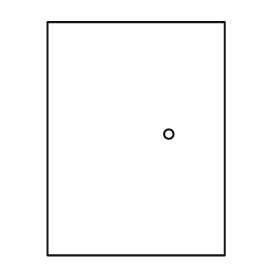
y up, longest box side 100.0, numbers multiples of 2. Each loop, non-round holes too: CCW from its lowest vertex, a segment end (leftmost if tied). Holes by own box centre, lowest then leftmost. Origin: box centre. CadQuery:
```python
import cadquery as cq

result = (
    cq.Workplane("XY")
    .moveTo(-38.0, -50.0)
    .lineTo(38.0, -50.0)
    .lineTo(38.0, 50.0)
    .lineTo(-38.0, 50.0)
    .close()
    .moveTo(14.0, 2.0)
    .circle(2.0)
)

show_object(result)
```